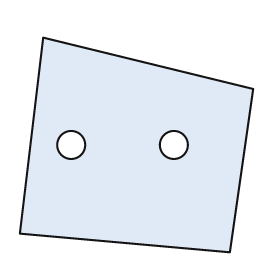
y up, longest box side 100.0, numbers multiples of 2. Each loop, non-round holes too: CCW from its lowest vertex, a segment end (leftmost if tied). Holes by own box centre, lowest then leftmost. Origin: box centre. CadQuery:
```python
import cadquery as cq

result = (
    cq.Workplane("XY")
    .moveTo(40.0, -46.0)
    .lineTo(50.0, 24.0)
    .lineTo(-40.0, 46.0)
    .lineTo(-50.0, -38.0)
    .close()
    .moveTo(-28.0, 0.0)
    .circle(6.0)
    .moveTo(16.0, 0.0)
    .circle(6.0)
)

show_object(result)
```